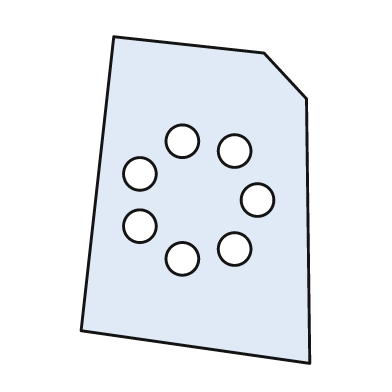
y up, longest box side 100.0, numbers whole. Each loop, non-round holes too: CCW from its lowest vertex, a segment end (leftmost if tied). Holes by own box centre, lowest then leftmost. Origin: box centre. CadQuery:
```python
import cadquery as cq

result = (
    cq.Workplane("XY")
    .moveTo(35.0, -50.0)
    .lineTo(34.0, 31.0)
    .lineTo(21.0, 45.0)
    .lineTo(-25.0, 50.0)
    .lineTo(-35.0, -40.0)
    .close()
    .moveTo(-4.0, -18.0)
    .circle(5.0)
    .moveTo(12.0, -15.0)
    .circle(5.0)
    .moveTo(-17.0, -8.0)
    .circle(5.0)
    .moveTo(19.0, 0.0)
    .circle(5.0)
    .moveTo(-17.0, 8.0)
    .circle(5.0)
    .moveTo(12.0, 15.0)
    .circle(5.0)
    .moveTo(-4.0, 18.0)
    .circle(5.0)
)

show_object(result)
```